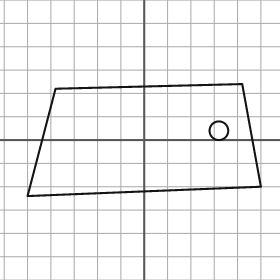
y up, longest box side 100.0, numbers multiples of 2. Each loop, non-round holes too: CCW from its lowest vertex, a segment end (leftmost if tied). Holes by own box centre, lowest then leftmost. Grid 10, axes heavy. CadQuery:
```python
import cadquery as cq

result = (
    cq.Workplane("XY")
    .moveTo(-50.0, -24.0)
    .lineTo(50.0, -20.0)
    .lineTo(42.0, 24.0)
    .lineTo(-38.0, 22.0)
    .close()
    .moveTo(32.0, 4.0)
    .circle(4.0)
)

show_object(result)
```